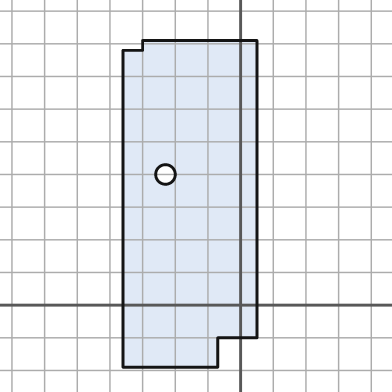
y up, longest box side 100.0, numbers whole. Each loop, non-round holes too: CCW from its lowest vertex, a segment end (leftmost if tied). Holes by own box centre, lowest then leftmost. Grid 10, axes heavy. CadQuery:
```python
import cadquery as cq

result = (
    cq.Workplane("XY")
    .moveTo(-36.0, -19.0)
    .lineTo(-7.0, -19.0)
    .lineTo(-7.0, -10.0)
    .lineTo(5.0, -10.0)
    .lineTo(5.0, 81.0)
    .lineTo(-30.0, 81.0)
    .lineTo(-30.0, 78.0)
    .lineTo(-36.0, 78.0)
    .close()
    .moveTo(-23.0, 40.0)
    .circle(3.0)
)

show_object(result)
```